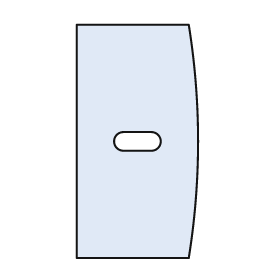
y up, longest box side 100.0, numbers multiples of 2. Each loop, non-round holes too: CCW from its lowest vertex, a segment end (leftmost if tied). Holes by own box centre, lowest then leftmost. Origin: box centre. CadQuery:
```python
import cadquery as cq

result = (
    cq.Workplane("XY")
    .moveTo(-26.0, -50.0)
    .lineTo(22.0, -50.0)
    .threePointArc((26.0, 0.0), (22.0, 50.0))
    .lineTo(-26.0, 50.0)
    .close()
    .moveTo(-6.0, -4.0)
    .lineTo(6.0, -4.0)
    .threePointArc((10.0, 0.0), (6.0, 4.0))
    .lineTo(-6.0, 4.0)
    .threePointArc((-10.0, 0.0), (-6.0, -4.0))
    .close()
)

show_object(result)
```